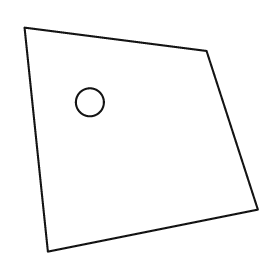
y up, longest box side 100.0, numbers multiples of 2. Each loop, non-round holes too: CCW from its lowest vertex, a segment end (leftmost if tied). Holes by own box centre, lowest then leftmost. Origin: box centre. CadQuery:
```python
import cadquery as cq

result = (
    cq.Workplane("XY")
    .moveTo(-40.0, -48.0)
    .lineTo(50.0, -30.0)
    .lineTo(28.0, 38.0)
    .lineTo(-50.0, 48.0)
    .close()
    .moveTo(-22.0, 16.0)
    .circle(6.0)
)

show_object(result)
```